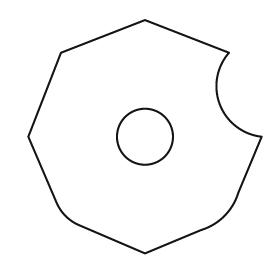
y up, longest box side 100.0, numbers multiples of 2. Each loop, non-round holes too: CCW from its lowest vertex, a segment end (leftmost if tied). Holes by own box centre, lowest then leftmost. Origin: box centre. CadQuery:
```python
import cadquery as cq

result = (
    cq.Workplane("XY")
    .moveTo(0.0, -50.0)
    .lineTo(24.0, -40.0)
    .threePointArc((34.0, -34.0), (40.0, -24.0))
    .lineTo(50.0, 0.0)
    .threePointArc((32.0, 14.0), (36.0, 36.0))
    .lineTo(0.0, 50.0)
    .lineTo(-36.0, 36.0)
    .lineTo(-50.0, 0.0)
    .lineTo(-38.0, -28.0)
    .threePointArc((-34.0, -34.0), (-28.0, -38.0))
    .close()
    .moveTo(0.0, 0.0)
    .circle(12.0)
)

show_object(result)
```